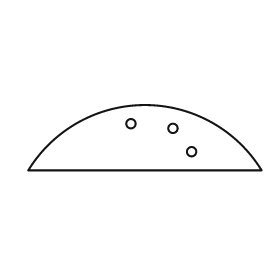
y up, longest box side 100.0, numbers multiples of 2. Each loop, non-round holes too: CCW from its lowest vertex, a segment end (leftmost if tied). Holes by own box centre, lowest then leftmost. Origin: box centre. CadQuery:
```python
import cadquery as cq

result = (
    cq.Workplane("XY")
    .moveTo(-50.0, -14.0)
    .lineTo(50.0, -14.0)
    .threePointArc((0.0, 14.0), (-50.0, -14.0))
    .close()
    .moveTo(20.0, -6.0)
    .circle(2.0)
    .moveTo(12.0, 4.0)
    .circle(2.0)
    .moveTo(-6.0, 6.0)
    .circle(2.0)
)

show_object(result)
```